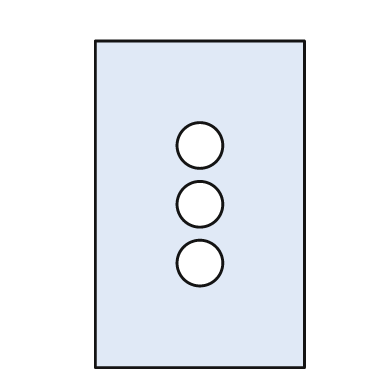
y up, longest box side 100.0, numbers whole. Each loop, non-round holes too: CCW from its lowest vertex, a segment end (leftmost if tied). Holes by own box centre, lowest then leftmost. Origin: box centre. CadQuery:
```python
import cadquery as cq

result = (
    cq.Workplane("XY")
    .moveTo(-32.0, -50.0)
    .lineTo(32.0, -50.0)
    .lineTo(32.0, 50.0)
    .lineTo(-32.0, 50.0)
    .close()
    .moveTo(0.0, -18.0)
    .circle(7.0)
    .moveTo(0.0, 0.0)
    .circle(7.0)
    .moveTo(0.0, 18.0)
    .circle(7.0)
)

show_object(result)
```